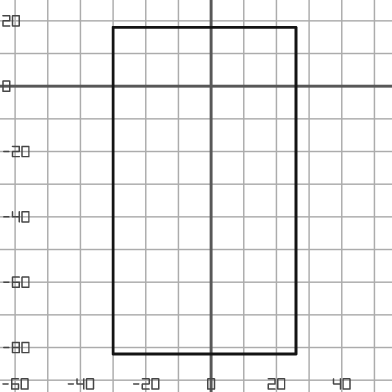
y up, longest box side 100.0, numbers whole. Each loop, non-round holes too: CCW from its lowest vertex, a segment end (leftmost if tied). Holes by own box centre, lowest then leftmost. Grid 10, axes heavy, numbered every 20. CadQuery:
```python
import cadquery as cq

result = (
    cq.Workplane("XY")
    .moveTo(-30.0, -82.0)
    .lineTo(26.0, -82.0)
    .lineTo(26.0, 18.0)
    .lineTo(-30.0, 18.0)
    .close()
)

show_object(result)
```